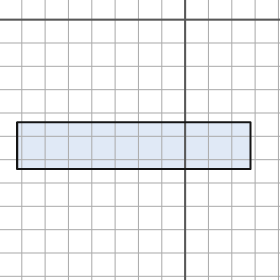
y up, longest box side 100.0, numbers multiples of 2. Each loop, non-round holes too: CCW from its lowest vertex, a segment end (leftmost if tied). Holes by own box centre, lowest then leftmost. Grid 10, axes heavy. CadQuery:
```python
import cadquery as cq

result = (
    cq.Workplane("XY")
    .moveTo(-72.0, -64.0)
    .lineTo(28.0, -64.0)
    .lineTo(28.0, -44.0)
    .lineTo(-72.0, -44.0)
    .close()
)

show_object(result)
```